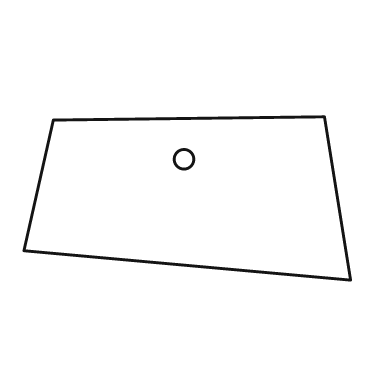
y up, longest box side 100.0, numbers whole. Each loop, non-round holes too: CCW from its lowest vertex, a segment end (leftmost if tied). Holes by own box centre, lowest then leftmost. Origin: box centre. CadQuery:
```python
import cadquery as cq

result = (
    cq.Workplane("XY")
    .moveTo(50.0, -25.0)
    .lineTo(42.0, 25.0)
    .lineTo(-41.0, 24.0)
    .lineTo(-50.0, -16.0)
    .close()
    .moveTo(-1.0, 12.0)
    .circle(3.0)
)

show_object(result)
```